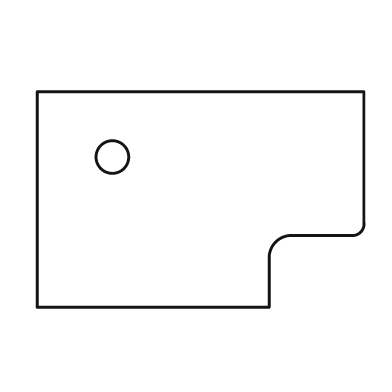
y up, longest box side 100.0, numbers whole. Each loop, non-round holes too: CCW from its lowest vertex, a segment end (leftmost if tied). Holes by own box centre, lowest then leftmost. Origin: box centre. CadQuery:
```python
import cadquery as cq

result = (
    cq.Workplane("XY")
    .moveTo(-50.0, -33.0)
    .lineTo(21.0, -33.0)
    .lineTo(21.0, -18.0)
    .threePointArc((23.0, -13.0), (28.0, -11.0))
    .lineTo(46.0, -11.0)
    .threePointArc((49.0, -10.0), (50.0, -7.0))
    .lineTo(50.0, 33.0)
    .lineTo(-50.0, 33.0)
    .close()
    .moveTo(-27.0, 13.0)
    .circle(5.0)
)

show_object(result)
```